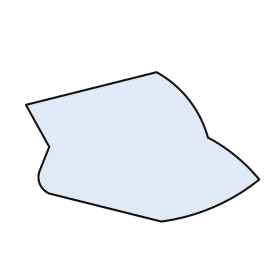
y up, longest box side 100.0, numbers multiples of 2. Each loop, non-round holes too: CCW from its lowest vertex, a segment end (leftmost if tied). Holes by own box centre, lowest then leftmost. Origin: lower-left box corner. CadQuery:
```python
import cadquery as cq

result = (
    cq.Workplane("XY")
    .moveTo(58.0, 0.0)
    .threePointArc((80.0, 6.0), (100.0, 18.0))
    .threePointArc((90.0, 28.0), (78.0, 36.0))
    .threePointArc((70.0, 52.0), (56.0, 64.0))
    .lineTo(0.0, 50.0)
    .lineTo(10.0, 32.0)
    .lineTo(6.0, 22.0)
    .threePointArc((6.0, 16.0), (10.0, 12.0))
    .close()
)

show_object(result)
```